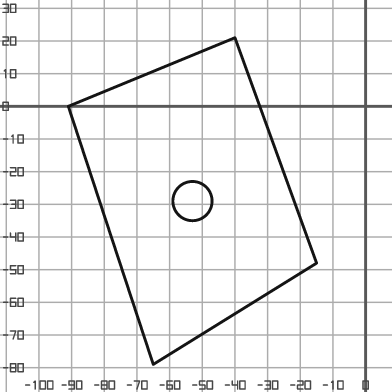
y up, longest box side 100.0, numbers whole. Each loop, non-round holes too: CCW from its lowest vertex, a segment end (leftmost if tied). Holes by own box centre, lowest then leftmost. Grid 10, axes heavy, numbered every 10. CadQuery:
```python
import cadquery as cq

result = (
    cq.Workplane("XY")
    .moveTo(-65.0, -79.0)
    .lineTo(-15.0, -48.0)
    .lineTo(-40.0, 21.0)
    .lineTo(-91.0, 0.0)
    .close()
    .moveTo(-53.0, -29.0)
    .circle(6.0)
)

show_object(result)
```